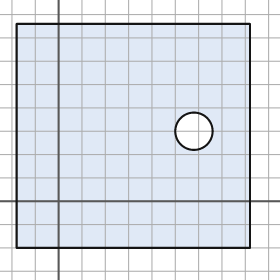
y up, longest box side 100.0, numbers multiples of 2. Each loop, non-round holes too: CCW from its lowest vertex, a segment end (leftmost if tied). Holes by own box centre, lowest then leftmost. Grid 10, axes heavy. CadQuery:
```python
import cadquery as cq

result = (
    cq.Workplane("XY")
    .moveTo(-18.0, -20.0)
    .lineTo(82.0, -20.0)
    .lineTo(82.0, 76.0)
    .lineTo(-18.0, 76.0)
    .close()
    .moveTo(58.0, 30.0)
    .circle(8.0)
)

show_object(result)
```